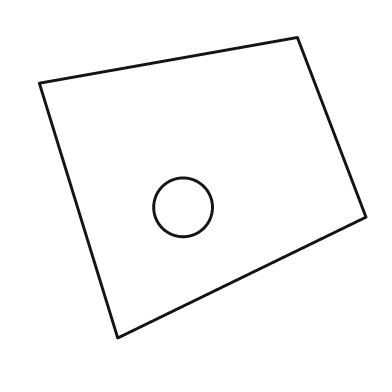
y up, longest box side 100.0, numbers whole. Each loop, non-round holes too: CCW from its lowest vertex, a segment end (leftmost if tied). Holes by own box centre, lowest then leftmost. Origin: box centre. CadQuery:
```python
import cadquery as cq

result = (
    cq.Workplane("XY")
    .moveTo(-26.0, -46.0)
    .lineTo(50.0, -9.0)
    .lineTo(29.0, 46.0)
    .lineTo(-50.0, 32.0)
    .close()
    .moveTo(-6.0, -6.0)
    .circle(9.0)
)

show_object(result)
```